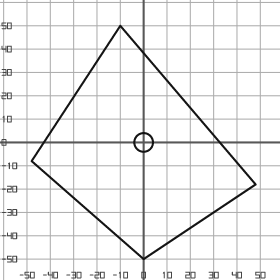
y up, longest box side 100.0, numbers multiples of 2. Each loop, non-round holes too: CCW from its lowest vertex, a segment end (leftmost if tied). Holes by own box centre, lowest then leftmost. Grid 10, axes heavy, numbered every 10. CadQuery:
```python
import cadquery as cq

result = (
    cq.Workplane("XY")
    .moveTo(0.0, -50.0)
    .lineTo(48.0, -18.0)
    .lineTo(-10.0, 50.0)
    .lineTo(-48.0, -8.0)
    .close()
    .moveTo(0.0, 0.0)
    .circle(4.0)
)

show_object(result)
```